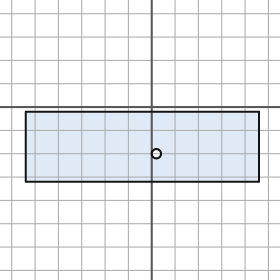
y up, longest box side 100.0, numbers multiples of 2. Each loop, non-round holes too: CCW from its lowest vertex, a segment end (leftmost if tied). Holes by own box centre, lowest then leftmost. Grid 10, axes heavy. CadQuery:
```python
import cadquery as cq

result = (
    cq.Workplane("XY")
    .moveTo(-54.0, -32.0)
    .lineTo(46.0, -32.0)
    .lineTo(46.0, -2.0)
    .lineTo(-54.0, -2.0)
    .close()
    .moveTo(2.0, -20.0)
    .circle(2.0)
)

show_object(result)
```